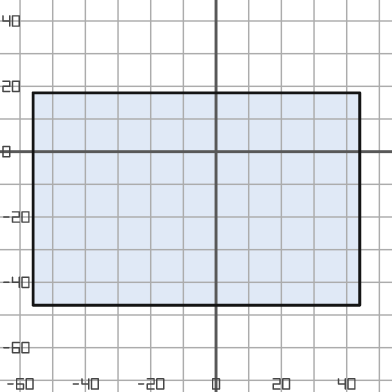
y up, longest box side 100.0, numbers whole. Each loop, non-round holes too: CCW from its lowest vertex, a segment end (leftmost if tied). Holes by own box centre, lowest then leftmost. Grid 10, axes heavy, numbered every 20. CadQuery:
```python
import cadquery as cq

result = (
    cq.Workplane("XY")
    .moveTo(-56.0, -47.0)
    .lineTo(44.0, -47.0)
    .lineTo(44.0, 18.0)
    .lineTo(-56.0, 18.0)
    .close()
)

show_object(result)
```